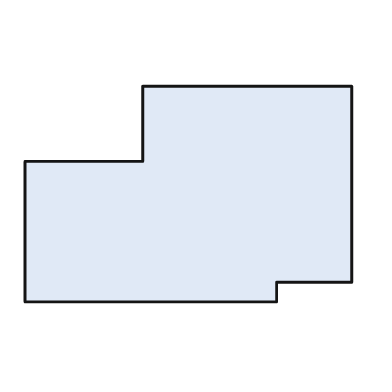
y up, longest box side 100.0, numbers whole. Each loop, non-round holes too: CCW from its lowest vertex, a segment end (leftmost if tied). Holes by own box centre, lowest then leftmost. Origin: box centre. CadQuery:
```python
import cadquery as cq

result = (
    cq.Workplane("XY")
    .moveTo(-50.0, -33.0)
    .lineTo(27.0, -33.0)
    .lineTo(27.0, -27.0)
    .lineTo(50.0, -27.0)
    .lineTo(50.0, 33.0)
    .lineTo(-14.0, 33.0)
    .lineTo(-14.0, 10.0)
    .lineTo(-50.0, 10.0)
    .close()
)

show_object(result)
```